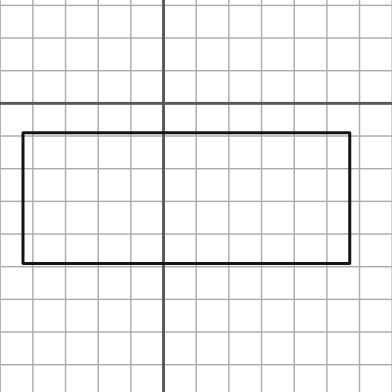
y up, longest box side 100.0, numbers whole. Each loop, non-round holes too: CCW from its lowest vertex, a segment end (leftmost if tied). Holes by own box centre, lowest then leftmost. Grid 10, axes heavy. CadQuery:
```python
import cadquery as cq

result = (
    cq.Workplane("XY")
    .moveTo(-43.0, -49.0)
    .lineTo(57.0, -49.0)
    .lineTo(57.0, -9.0)
    .lineTo(-43.0, -9.0)
    .close()
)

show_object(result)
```